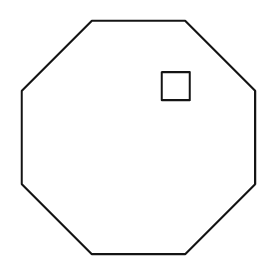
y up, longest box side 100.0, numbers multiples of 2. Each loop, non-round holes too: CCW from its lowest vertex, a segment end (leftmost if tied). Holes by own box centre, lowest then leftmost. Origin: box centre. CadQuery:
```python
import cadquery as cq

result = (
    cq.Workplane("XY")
    .moveTo(-20.0, -50.0)
    .lineTo(20.0, -50.0)
    .lineTo(50.0, -20.0)
    .lineTo(50.0, 20.0)
    .lineTo(20.0, 50.0)
    .lineTo(-20.0, 50.0)
    .lineTo(-50.0, 20.0)
    .lineTo(-50.0, -20.0)
    .close()
    .moveTo(10.0, 16.0)
    .lineTo(22.0, 16.0)
    .lineTo(22.0, 28.0)
    .lineTo(10.0, 28.0)
    .close()
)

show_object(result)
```